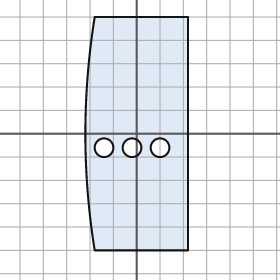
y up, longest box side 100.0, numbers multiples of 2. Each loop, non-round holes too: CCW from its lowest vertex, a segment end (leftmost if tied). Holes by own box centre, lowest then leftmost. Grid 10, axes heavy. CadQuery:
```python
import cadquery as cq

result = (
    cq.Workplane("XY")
    .moveTo(-18.0, -50.0)
    .lineTo(22.0, -50.0)
    .lineTo(22.0, 50.0)
    .lineTo(-18.0, 50.0)
    .threePointArc((-22.0, 0.0), (-18.0, -50.0))
    .close()
    .moveTo(-14.0, -6.0)
    .circle(4.0)
    .moveTo(-2.0, -6.0)
    .circle(4.0)
    .moveTo(10.0, -6.0)
    .circle(4.0)
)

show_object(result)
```